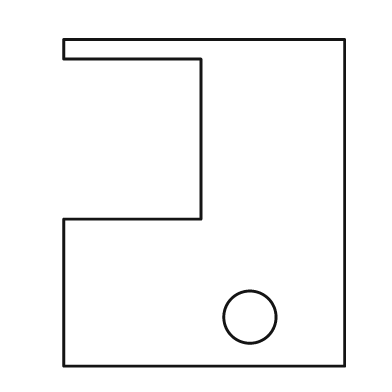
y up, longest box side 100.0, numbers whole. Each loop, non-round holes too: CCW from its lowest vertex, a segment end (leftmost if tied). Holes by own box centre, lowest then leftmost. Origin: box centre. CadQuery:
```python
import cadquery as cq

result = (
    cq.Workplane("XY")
    .moveTo(-43.0, -50.0)
    .lineTo(43.0, -50.0)
    .lineTo(43.0, 50.0)
    .lineTo(-43.0, 50.0)
    .lineTo(-43.0, 44.0)
    .lineTo(-1.0, 44.0)
    .lineTo(-1.0, -5.0)
    .lineTo(-43.0, -5.0)
    .close()
    .moveTo(14.0, -35.0)
    .circle(8.0)
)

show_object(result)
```